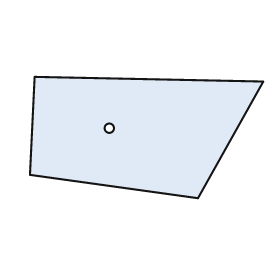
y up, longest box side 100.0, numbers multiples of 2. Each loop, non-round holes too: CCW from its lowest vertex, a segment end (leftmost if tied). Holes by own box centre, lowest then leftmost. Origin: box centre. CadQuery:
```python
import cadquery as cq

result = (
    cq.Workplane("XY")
    .moveTo(22.0, -26.0)
    .lineTo(50.0, 24.0)
    .lineTo(-48.0, 26.0)
    .lineTo(-50.0, -16.0)
    .close()
    .moveTo(-16.0, 4.0)
    .circle(2.0)
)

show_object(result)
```